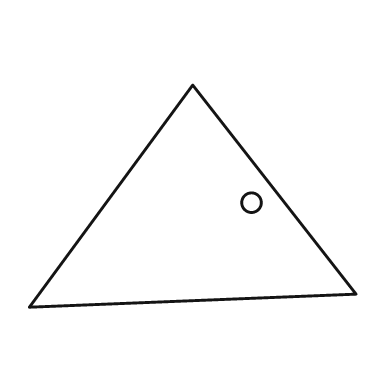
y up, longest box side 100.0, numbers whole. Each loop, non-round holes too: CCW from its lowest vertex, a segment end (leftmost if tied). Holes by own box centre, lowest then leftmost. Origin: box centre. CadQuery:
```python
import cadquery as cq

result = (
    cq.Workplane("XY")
    .moveTo(-50.0, -34.0)
    .lineTo(50.0, -30.0)
    .lineTo(0.0, 34.0)
    .close()
    .moveTo(18.0, -2.0)
    .circle(3.0)
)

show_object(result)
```